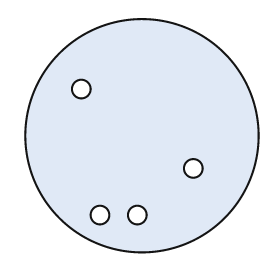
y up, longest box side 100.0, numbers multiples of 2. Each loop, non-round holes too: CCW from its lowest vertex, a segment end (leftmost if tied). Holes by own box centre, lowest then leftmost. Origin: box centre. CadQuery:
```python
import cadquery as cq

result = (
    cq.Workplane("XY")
    .moveTo(0.0, 0.0)
    .circle(50.0)
    .moveTo(-18.0, -34.0)
    .circle(4.0)
    .moveTo(-2.0, -34.0)
    .circle(4.0)
    .moveTo(22.0, -14.0)
    .circle(4.0)
    .moveTo(-26.0, 20.0)
    .circle(4.0)
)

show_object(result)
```